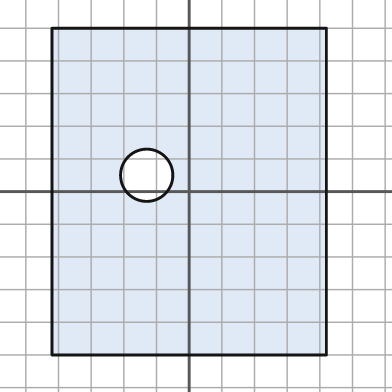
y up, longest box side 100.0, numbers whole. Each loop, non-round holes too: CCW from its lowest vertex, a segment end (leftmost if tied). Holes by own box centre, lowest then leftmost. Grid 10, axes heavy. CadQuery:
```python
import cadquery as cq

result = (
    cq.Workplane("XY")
    .moveTo(-42.0, -50.0)
    .lineTo(42.0, -50.0)
    .lineTo(42.0, 50.0)
    .lineTo(-42.0, 50.0)
    .close()
    .moveTo(-13.0, 5.0)
    .circle(8.0)
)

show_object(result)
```